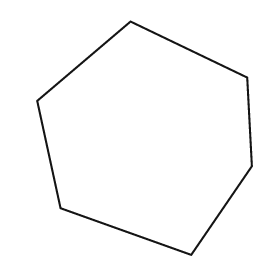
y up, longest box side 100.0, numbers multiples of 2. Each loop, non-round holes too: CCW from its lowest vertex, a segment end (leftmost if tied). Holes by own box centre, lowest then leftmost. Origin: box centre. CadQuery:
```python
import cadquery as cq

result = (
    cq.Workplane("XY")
    .moveTo(20.0, -50.0)
    .lineTo(46.0, -12.0)
    .lineTo(44.0, 26.0)
    .lineTo(-6.0, 50.0)
    .lineTo(-46.0, 16.0)
    .lineTo(-36.0, -30.0)
    .close()
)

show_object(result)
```